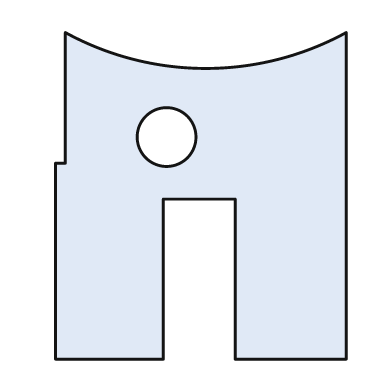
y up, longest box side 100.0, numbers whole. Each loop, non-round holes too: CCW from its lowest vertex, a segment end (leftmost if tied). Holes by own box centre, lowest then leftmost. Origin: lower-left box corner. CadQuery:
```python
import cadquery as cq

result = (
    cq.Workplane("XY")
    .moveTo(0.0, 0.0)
    .lineTo(33.0, 0.0)
    .lineTo(33.0, 49.0)
    .lineTo(55.0, 49.0)
    .lineTo(55.0, 0.0)
    .lineTo(89.0, 0.0)
    .lineTo(89.0, 100.0)
    .threePointArc((46.0, 89.0), (3.0, 100.0))
    .lineTo(3.0, 60.0)
    .lineTo(0.0, 60.0)
    .close()
    .moveTo(34.0, 68.0)
    .circle(9.0)
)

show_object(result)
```